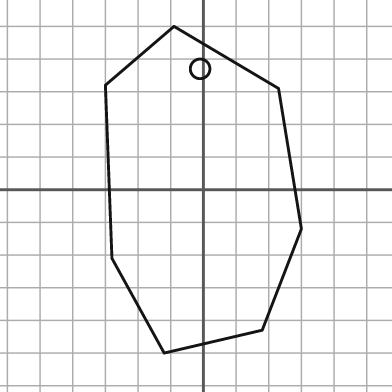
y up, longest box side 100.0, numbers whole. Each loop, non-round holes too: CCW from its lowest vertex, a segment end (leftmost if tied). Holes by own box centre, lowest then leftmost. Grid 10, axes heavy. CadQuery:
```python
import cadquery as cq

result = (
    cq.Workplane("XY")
    .moveTo(-12.0, -50.0)
    .lineTo(18.0, -43.0)
    .lineTo(30.0, -12.0)
    .lineTo(23.0, 31.0)
    .lineTo(-9.0, 50.0)
    .lineTo(-30.0, 32.0)
    .lineTo(-28.0, -21.0)
    .close()
    .moveTo(-1.0, 37.0)
    .circle(3.0)
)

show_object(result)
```